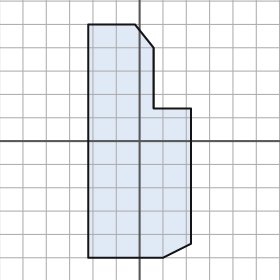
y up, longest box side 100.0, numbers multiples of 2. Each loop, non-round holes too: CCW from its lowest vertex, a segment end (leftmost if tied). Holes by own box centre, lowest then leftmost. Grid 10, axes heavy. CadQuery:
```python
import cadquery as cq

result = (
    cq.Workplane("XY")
    .moveTo(-22.0, -50.0)
    .lineTo(10.0, -50.0)
    .lineTo(22.0, -44.0)
    .lineTo(22.0, 14.0)
    .lineTo(6.0, 14.0)
    .lineTo(6.0, 40.0)
    .lineTo(-2.0, 50.0)
    .lineTo(-22.0, 50.0)
    .close()
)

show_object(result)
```